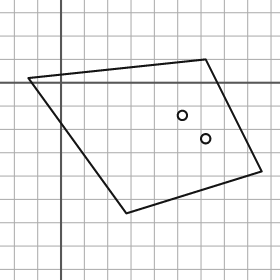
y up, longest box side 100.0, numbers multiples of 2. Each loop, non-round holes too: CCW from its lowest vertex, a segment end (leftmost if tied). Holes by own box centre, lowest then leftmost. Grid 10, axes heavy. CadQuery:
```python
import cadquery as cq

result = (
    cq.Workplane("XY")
    .moveTo(28.0, -56.0)
    .lineTo(86.0, -38.0)
    .lineTo(62.0, 10.0)
    .lineTo(-14.0, 2.0)
    .close()
    .moveTo(62.0, -24.0)
    .circle(2.0)
    .moveTo(52.0, -14.0)
    .circle(2.0)
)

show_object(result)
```